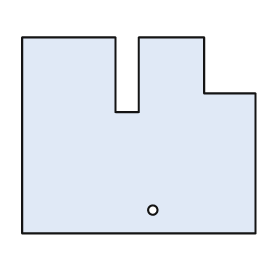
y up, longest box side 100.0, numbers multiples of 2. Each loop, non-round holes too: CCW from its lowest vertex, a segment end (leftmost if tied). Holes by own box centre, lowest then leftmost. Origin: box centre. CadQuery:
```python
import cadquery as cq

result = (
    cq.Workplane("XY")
    .moveTo(-50.0, -42.0)
    .lineTo(50.0, -42.0)
    .lineTo(50.0, 18.0)
    .lineTo(28.0, 18.0)
    .lineTo(28.0, 42.0)
    .lineTo(0.0, 42.0)
    .lineTo(0.0, 10.0)
    .lineTo(-10.0, 10.0)
    .lineTo(-10.0, 42.0)
    .lineTo(-50.0, 42.0)
    .close()
    .moveTo(6.0, -32.0)
    .circle(2.0)
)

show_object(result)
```